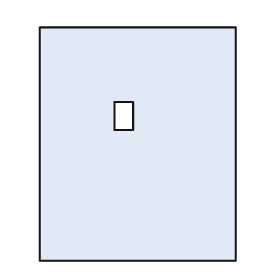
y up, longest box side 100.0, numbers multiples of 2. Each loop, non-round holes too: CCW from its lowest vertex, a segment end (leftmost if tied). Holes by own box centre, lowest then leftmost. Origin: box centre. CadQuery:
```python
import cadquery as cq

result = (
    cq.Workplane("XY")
    .moveTo(-42.0, -50.0)
    .lineTo(42.0, -50.0)
    .lineTo(42.0, 50.0)
    .lineTo(-42.0, 50.0)
    .close()
    .moveTo(-10.0, 6.0)
    .lineTo(-2.0, 6.0)
    .lineTo(-2.0, 18.0)
    .lineTo(-10.0, 18.0)
    .close()
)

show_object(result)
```